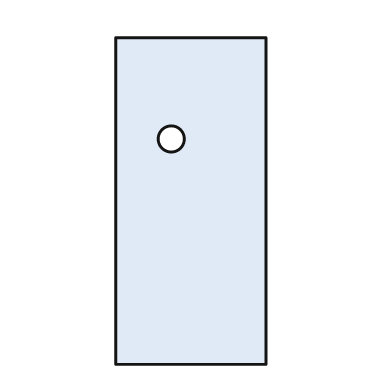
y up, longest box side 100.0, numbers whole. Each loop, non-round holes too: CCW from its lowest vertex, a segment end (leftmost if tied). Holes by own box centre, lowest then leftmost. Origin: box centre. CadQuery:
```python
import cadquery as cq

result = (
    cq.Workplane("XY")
    .moveTo(-23.0, -50.0)
    .lineTo(23.0, -50.0)
    .lineTo(23.0, 50.0)
    .lineTo(-23.0, 50.0)
    .close()
    .moveTo(-6.0, 19.0)
    .circle(4.0)
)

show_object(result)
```